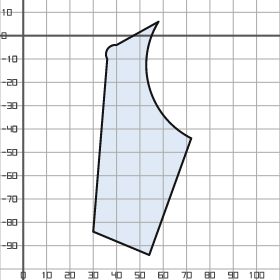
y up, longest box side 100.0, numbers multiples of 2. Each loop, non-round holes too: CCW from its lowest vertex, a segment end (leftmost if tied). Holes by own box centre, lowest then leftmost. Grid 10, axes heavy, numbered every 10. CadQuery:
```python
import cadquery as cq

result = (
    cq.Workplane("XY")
    .moveTo(54.0, -94.0)
    .lineTo(72.0, -44.0)
    .threePointArc((54.0, -22.0), (58.0, 6.0))
    .lineTo(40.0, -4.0)
    .threePointArc((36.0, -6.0), (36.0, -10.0))
    .lineTo(30.0, -84.0)
    .close()
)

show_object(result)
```